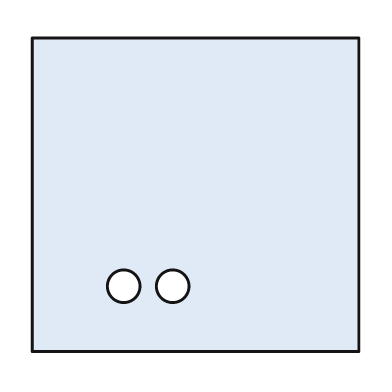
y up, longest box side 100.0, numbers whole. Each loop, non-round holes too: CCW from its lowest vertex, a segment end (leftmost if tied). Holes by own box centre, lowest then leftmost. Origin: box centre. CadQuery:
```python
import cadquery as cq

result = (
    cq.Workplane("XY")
    .moveTo(-50.0, -48.0)
    .lineTo(50.0, -48.0)
    .lineTo(50.0, 48.0)
    .lineTo(-50.0, 48.0)
    .close()
    .moveTo(-22.0, -28.0)
    .circle(5.0)
    .moveTo(-7.0, -28.0)
    .circle(5.0)
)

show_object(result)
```